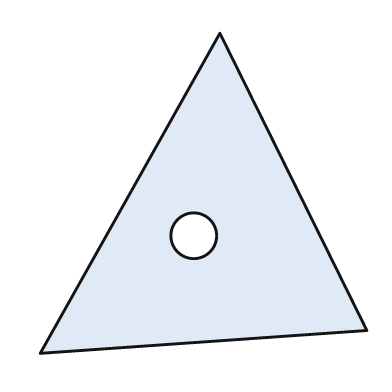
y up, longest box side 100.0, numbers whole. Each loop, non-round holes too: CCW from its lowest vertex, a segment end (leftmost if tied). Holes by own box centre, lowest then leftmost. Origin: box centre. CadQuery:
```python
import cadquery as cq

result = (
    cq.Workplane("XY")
    .moveTo(-50.0, -49.0)
    .lineTo(50.0, -42.0)
    .lineTo(5.0, 49.0)
    .close()
    .moveTo(-3.0, -13.0)
    .circle(7.0)
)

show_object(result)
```